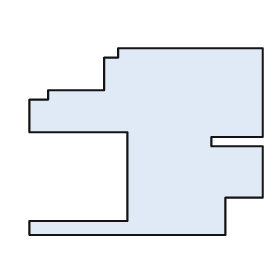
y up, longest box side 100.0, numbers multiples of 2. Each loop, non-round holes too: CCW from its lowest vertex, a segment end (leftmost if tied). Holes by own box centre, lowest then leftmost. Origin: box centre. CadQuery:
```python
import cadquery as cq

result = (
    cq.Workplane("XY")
    .moveTo(-50.0, -40.0)
    .lineTo(34.0, -40.0)
    .lineTo(34.0, -24.0)
    .lineTo(50.0, -24.0)
    .lineTo(50.0, -2.0)
    .lineTo(28.0, -2.0)
    .lineTo(28.0, 2.0)
    .lineTo(50.0, 2.0)
    .lineTo(50.0, 40.0)
    .lineTo(-12.0, 40.0)
    .lineTo(-12.0, 36.0)
    .lineTo(-18.0, 36.0)
    .lineTo(-18.0, 22.0)
    .lineTo(-42.0, 22.0)
    .lineTo(-42.0, 18.0)
    .lineTo(-50.0, 18.0)
    .lineTo(-50.0, 4.0)
    .lineTo(-8.0, 4.0)
    .lineTo(-8.0, -34.0)
    .lineTo(-50.0, -34.0)
    .close()
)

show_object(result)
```